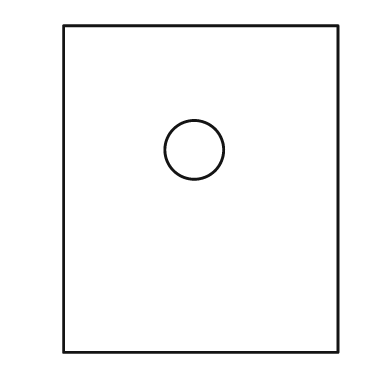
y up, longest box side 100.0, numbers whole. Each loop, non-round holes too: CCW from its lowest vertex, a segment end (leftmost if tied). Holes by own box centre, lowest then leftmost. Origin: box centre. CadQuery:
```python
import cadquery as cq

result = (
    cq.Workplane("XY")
    .moveTo(-42.0, -50.0)
    .lineTo(42.0, -50.0)
    .lineTo(42.0, 50.0)
    .lineTo(-42.0, 50.0)
    .close()
    .moveTo(-2.0, 12.0)
    .circle(9.0)
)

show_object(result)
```